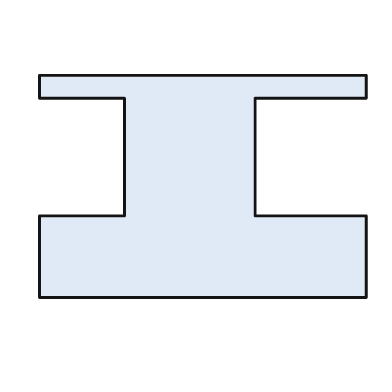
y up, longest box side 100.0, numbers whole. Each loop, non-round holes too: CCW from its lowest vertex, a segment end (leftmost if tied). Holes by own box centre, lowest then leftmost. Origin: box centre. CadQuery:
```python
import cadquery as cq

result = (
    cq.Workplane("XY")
    .moveTo(-50.0, -34.0)
    .lineTo(50.0, -34.0)
    .lineTo(50.0, -9.0)
    .lineTo(16.0, -9.0)
    .lineTo(16.0, 27.0)
    .lineTo(50.0, 27.0)
    .lineTo(50.0, 34.0)
    .lineTo(-50.0, 34.0)
    .lineTo(-50.0, 27.0)
    .lineTo(-24.0, 27.0)
    .lineTo(-24.0, -9.0)
    .lineTo(-50.0, -9.0)
    .close()
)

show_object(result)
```